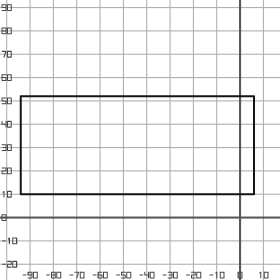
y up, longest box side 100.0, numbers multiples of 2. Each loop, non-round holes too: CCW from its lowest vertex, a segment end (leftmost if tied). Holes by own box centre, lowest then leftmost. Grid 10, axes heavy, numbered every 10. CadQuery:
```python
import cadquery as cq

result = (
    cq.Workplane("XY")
    .moveTo(-94.0, 10.0)
    .lineTo(6.0, 10.0)
    .lineTo(6.0, 52.0)
    .lineTo(-94.0, 52.0)
    .close()
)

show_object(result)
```